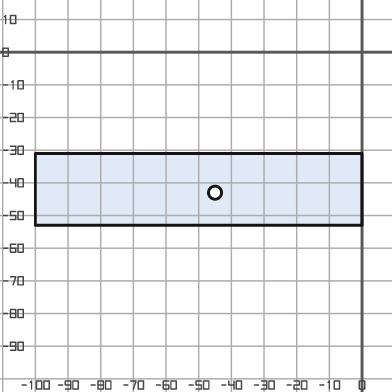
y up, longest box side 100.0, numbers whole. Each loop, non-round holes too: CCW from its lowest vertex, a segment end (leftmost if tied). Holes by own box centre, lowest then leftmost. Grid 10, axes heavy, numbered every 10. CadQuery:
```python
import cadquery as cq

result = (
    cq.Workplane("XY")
    .moveTo(-100.0, -53.0)
    .lineTo(0.0, -53.0)
    .lineTo(0.0, -31.0)
    .lineTo(-100.0, -31.0)
    .close()
    .moveTo(-45.0, -43.0)
    .circle(2.0)
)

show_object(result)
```